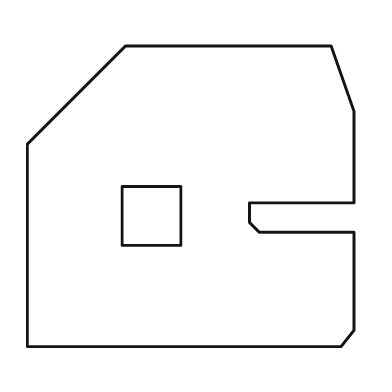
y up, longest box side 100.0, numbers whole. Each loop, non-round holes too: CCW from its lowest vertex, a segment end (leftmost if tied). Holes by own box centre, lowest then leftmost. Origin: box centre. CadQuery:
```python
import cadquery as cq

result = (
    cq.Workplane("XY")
    .moveTo(-50.0, -46.0)
    .lineTo(46.0, -46.0)
    .lineTo(50.0, -41.0)
    .lineTo(50.0, -11.0)
    .lineTo(21.0, -11.0)
    .lineTo(18.0, -8.0)
    .lineTo(18.0, -2.0)
    .lineTo(50.0, -2.0)
    .lineTo(50.0, 26.0)
    .lineTo(43.0, 46.0)
    .lineTo(-20.0, 46.0)
    .lineTo(-50.0, 16.0)
    .close()
    .moveTo(-21.0, -15.0)
    .lineTo(-3.0, -15.0)
    .lineTo(-3.0, 3.0)
    .lineTo(-21.0, 3.0)
    .close()
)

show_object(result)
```